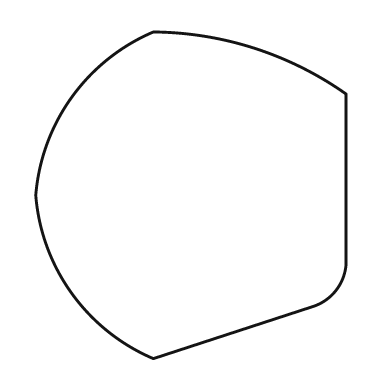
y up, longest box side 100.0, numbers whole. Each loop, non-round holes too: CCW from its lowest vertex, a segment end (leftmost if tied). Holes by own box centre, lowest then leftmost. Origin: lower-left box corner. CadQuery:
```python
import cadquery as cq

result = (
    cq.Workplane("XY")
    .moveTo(36.0, 0.0)
    .lineTo(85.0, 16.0)
    .threePointArc((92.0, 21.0), (95.0, 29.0))
    .lineTo(95.0, 81.0)
    .threePointArc((67.0, 95.0), (36.0, 100.0))
    .threePointArc((11.0, 80.0), (0.0, 50.0))
    .threePointArc((11.0, 20.0), (36.0, 0.0))
    .close()
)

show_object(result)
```